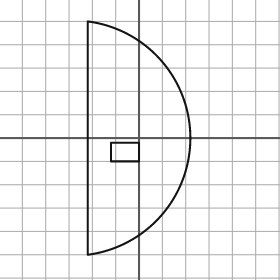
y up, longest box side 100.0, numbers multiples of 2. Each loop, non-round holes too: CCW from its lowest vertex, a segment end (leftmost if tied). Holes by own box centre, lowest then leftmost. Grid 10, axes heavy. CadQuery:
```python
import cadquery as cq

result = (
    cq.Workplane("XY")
    .moveTo(-22.0, -50.0)
    .threePointArc((22.0, 0.0), (-22.0, 50.0))
    .close()
    .moveTo(-12.0, -10.0)
    .lineTo(0.0, -10.0)
    .lineTo(0.0, -2.0)
    .lineTo(-12.0, -2.0)
    .close()
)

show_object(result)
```